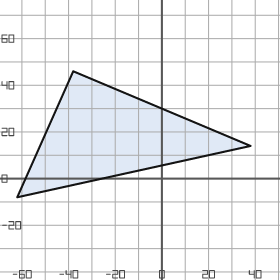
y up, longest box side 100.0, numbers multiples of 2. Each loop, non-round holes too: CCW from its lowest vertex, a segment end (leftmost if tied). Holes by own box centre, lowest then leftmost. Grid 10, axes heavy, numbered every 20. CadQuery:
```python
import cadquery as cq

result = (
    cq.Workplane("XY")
    .moveTo(-62.0, -8.0)
    .lineTo(38.0, 14.0)
    .lineTo(-38.0, 46.0)
    .close()
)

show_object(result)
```